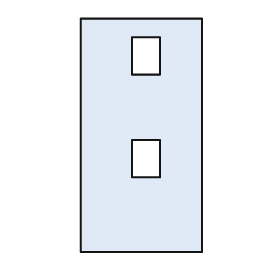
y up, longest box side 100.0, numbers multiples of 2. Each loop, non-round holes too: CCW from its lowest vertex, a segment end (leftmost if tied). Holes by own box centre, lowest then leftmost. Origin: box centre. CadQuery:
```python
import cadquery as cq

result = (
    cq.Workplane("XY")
    .moveTo(-26.0, -50.0)
    .lineTo(26.0, -50.0)
    .lineTo(26.0, 50.0)
    .lineTo(-26.0, 50.0)
    .close()
    .moveTo(-4.0, -18.0)
    .lineTo(8.0, -18.0)
    .lineTo(8.0, -2.0)
    .lineTo(-4.0, -2.0)
    .close()
    .moveTo(-4.0, 26.0)
    .lineTo(8.0, 26.0)
    .lineTo(8.0, 42.0)
    .lineTo(-4.0, 42.0)
    .close()
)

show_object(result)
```